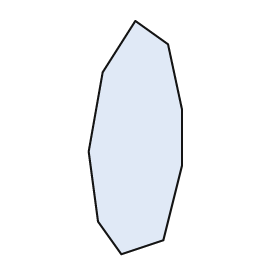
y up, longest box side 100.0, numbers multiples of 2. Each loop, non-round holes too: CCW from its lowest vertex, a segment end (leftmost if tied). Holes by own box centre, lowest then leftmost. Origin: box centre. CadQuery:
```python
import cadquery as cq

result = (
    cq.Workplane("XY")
    .moveTo(-6.0, -50.0)
    .lineTo(12.0, -44.0)
    .lineTo(20.0, -12.0)
    .lineTo(20.0, 12.0)
    .lineTo(14.0, 40.0)
    .lineTo(0.0, 50.0)
    .lineTo(-14.0, 28.0)
    .lineTo(-20.0, -6.0)
    .lineTo(-16.0, -36.0)
    .close()
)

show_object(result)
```